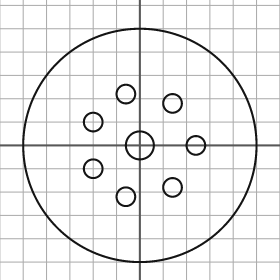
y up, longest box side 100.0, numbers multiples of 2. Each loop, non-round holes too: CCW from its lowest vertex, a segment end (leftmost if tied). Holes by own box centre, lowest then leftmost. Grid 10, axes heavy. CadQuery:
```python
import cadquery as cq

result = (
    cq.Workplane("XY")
    .moveTo(0.0, 0.0)
    .circle(50.0)
    .moveTo(-6.0, -22.0)
    .circle(4.0)
    .moveTo(14.0, -18.0)
    .circle(4.0)
    .moveTo(-20.0, -10.0)
    .circle(4.0)
    .moveTo(0.0, 0.0)
    .circle(6.0)
    .moveTo(24.0, 0.0)
    .circle(4.0)
    .moveTo(-20.0, 10.0)
    .circle(4.0)
    .moveTo(14.0, 18.0)
    .circle(4.0)
    .moveTo(-6.0, 22.0)
    .circle(4.0)
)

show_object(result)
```